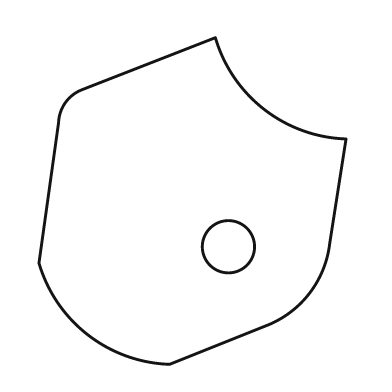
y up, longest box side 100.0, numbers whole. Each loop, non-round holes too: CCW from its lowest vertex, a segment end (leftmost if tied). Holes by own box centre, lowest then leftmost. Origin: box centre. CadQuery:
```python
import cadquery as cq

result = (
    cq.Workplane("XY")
    .moveTo(-7.0, -50.0)
    .lineTo(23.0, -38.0)
    .threePointArc((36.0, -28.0), (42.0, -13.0))
    .lineTo(47.0, 19.0)
    .threePointArc((22.0, 28.0), (7.0, 50.0))
    .lineTo(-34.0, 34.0)
    .threePointArc((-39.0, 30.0), (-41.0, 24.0))
    .lineTo(-47.0, -19.0)
    .threePointArc((-32.0, -41.0), (-7.0, -50.0))
    .close()
    .moveTo(11.0, -14.0)
    .circle(8.0)
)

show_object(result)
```